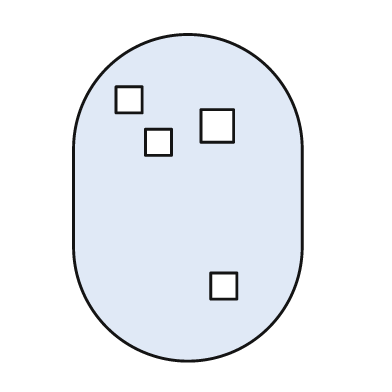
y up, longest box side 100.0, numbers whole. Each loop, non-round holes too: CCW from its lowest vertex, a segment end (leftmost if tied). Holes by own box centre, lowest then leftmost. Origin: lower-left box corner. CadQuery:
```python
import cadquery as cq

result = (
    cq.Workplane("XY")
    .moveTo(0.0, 35.0)
    .threePointArc((35.0, 0.0), (70.0, 35.0))
    .lineTo(70.0, 65.0)
    .threePointArc((35.0, 100.0), (0.0, 65.0))
    .close()
    .moveTo(42.0, 19.0)
    .lineTo(50.0, 19.0)
    .lineTo(50.0, 27.0)
    .lineTo(42.0, 27.0)
    .close()
    .moveTo(22.0, 63.0)
    .lineTo(30.0, 63.0)
    .lineTo(30.0, 71.0)
    .lineTo(22.0, 71.0)
    .close()
    .moveTo(39.0, 67.0)
    .lineTo(49.0, 67.0)
    .lineTo(49.0, 77.0)
    .lineTo(39.0, 77.0)
    .close()
    .moveTo(13.0, 76.0)
    .lineTo(21.0, 76.0)
    .lineTo(21.0, 84.0)
    .lineTo(13.0, 84.0)
    .close()
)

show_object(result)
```